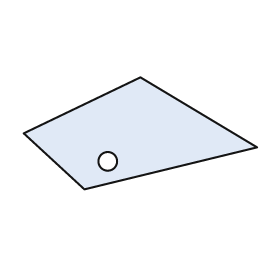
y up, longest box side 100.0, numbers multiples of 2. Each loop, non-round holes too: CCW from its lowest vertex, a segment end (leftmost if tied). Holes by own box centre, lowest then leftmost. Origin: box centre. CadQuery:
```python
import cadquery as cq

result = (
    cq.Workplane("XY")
    .moveTo(-24.0, -24.0)
    .lineTo(50.0, -6.0)
    .lineTo(0.0, 24.0)
    .lineTo(-50.0, 0.0)
    .close()
    .moveTo(-14.0, -12.0)
    .circle(4.0)
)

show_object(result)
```